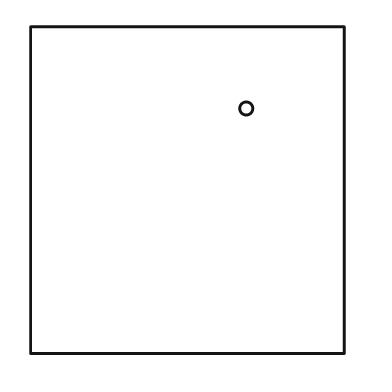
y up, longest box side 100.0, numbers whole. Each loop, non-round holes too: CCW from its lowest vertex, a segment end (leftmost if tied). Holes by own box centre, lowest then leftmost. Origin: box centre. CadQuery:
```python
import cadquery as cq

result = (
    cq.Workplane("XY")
    .moveTo(-48.0, -50.0)
    .lineTo(48.0, -50.0)
    .lineTo(48.0, 50.0)
    .lineTo(-48.0, 50.0)
    .close()
    .moveTo(18.0, 25.0)
    .circle(2.0)
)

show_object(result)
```